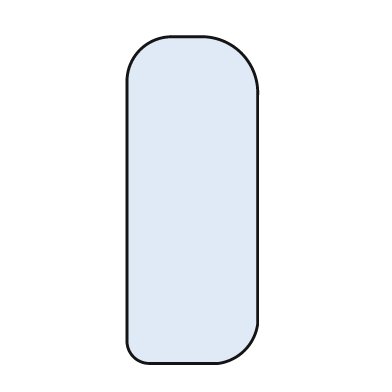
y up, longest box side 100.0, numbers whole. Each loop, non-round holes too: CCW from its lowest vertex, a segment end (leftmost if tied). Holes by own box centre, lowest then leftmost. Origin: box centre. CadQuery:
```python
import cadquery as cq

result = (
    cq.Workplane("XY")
    .moveTo(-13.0, -50.0)
    .lineTo(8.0, -50.0)
    .threePointArc((16.0, -46.0), (20.0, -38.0))
    .lineTo(20.0, 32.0)
    .threePointArc((15.0, 45.0), (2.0, 50.0))
    .lineTo(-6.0, 50.0)
    .threePointArc((-16.0, 46.0), (-20.0, 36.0))
    .lineTo(-20.0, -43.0)
    .threePointArc((-18.0, -48.0), (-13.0, -50.0))
    .close()
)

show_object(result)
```